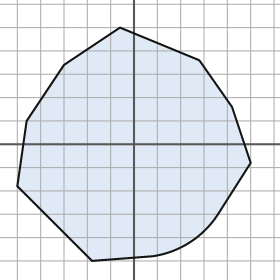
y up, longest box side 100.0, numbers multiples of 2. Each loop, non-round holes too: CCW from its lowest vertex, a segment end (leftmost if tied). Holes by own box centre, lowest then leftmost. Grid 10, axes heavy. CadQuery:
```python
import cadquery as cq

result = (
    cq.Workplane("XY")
    .moveTo(-18.0, -50.0)
    .lineTo(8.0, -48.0)
    .threePointArc((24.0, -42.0), (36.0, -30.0))
    .lineTo(50.0, -8.0)
    .lineTo(42.0, 16.0)
    .lineTo(28.0, 36.0)
    .lineTo(-6.0, 50.0)
    .lineTo(-30.0, 34.0)
    .lineTo(-46.0, 10.0)
    .lineTo(-50.0, -18.0)
    .close()
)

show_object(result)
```